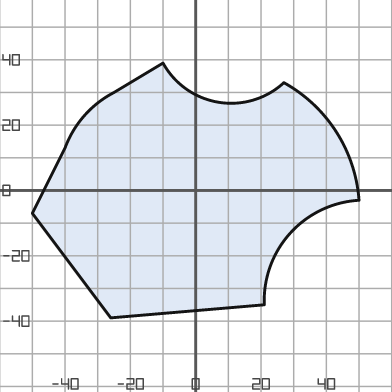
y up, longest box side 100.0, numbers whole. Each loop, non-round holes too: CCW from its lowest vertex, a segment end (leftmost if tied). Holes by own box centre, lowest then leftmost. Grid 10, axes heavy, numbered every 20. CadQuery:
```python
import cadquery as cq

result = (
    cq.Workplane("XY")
    .moveTo(-26.0, -39.0)
    .lineTo(21.0, -35.0)
    .threePointArc((29.0, -13.0), (50.0, -3.0))
    .threePointArc((43.0, 18.0), (27.0, 33.0))
    .threePointArc((7.0, 27.0), (-10.0, 39.0))
    .lineTo(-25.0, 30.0)
    .threePointArc((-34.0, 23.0), (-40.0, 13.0))
    .lineTo(-50.0, -7.0)
    .close()
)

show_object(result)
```